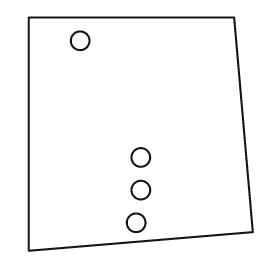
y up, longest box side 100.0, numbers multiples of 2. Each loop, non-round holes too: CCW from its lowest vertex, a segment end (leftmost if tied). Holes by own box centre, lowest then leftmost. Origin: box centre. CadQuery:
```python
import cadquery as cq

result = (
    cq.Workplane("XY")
    .moveTo(-48.0, -50.0)
    .lineTo(48.0, -42.0)
    .lineTo(40.0, 50.0)
    .lineTo(-48.0, 50.0)
    .close()
    .moveTo(-2.0, -38.0)
    .circle(4.0)
    .moveTo(0.0, -24.0)
    .circle(4.0)
    .moveTo(0.0, -10.0)
    .circle(4.0)
    .moveTo(-26.0, 40.0)
    .circle(4.0)
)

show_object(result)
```